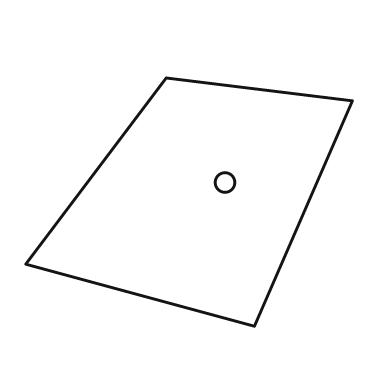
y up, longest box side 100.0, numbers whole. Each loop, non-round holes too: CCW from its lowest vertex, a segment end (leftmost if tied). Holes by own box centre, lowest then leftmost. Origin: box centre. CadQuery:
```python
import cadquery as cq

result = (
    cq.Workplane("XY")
    .moveTo(20.0, -38.0)
    .lineTo(50.0, 31.0)
    .lineTo(-7.0, 38.0)
    .lineTo(-50.0, -19.0)
    .close()
    .moveTo(11.0, 6.0)
    .circle(3.0)
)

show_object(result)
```